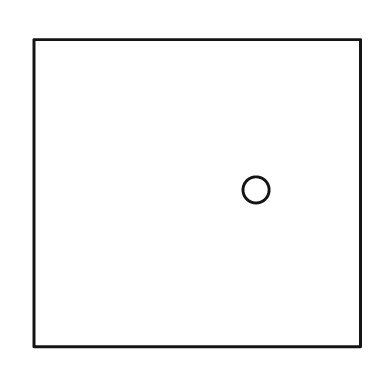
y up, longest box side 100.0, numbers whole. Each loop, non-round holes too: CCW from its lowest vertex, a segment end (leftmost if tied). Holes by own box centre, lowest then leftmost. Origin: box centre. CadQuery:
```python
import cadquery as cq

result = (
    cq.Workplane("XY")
    .moveTo(-50.0, -47.0)
    .lineTo(50.0, -47.0)
    .lineTo(50.0, 47.0)
    .lineTo(-50.0, 47.0)
    .close()
    .moveTo(18.0, 1.0)
    .circle(4.0)
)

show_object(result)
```